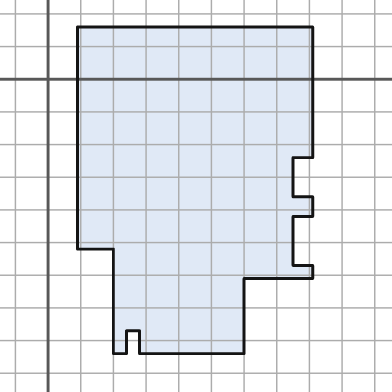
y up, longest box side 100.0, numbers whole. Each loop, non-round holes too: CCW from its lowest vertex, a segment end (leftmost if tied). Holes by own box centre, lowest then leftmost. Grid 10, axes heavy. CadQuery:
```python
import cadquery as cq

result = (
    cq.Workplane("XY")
    .moveTo(20.0, -84.0)
    .lineTo(24.0, -84.0)
    .lineTo(24.0, -77.0)
    .lineTo(28.0, -77.0)
    .lineTo(28.0, -84.0)
    .lineTo(60.0, -84.0)
    .lineTo(60.0, -61.0)
    .lineTo(81.0, -61.0)
    .lineTo(81.0, -57.0)
    .lineTo(75.0, -57.0)
    .lineTo(75.0, -42.0)
    .lineTo(81.0, -42.0)
    .lineTo(81.0, -36.0)
    .lineTo(75.0, -36.0)
    .lineTo(75.0, -24.0)
    .lineTo(81.0, -24.0)
    .lineTo(81.0, 16.0)
    .lineTo(9.0, 16.0)
    .lineTo(9.0, -52.0)
    .lineTo(20.0, -52.0)
    .close()
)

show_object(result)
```